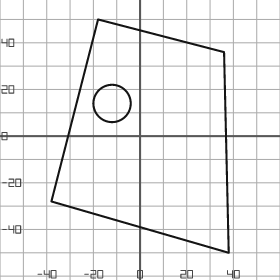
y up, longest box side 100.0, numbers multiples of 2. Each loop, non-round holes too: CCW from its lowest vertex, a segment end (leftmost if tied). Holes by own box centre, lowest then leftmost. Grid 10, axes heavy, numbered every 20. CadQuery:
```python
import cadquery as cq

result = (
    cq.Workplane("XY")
    .moveTo(38.0, -50.0)
    .lineTo(36.0, 36.0)
    .lineTo(-18.0, 50.0)
    .lineTo(-38.0, -28.0)
    .close()
    .moveTo(-12.0, 14.0)
    .circle(8.0)
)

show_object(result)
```